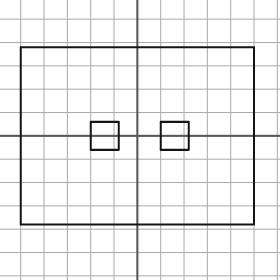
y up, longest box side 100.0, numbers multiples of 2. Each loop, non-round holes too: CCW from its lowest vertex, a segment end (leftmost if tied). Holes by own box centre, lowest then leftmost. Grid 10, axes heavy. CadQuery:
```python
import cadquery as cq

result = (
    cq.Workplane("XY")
    .moveTo(-50.0, -38.0)
    .lineTo(50.0, -38.0)
    .lineTo(50.0, 38.0)
    .lineTo(-50.0, 38.0)
    .close()
    .moveTo(-20.0, -6.0)
    .lineTo(-8.0, -6.0)
    .lineTo(-8.0, 6.0)
    .lineTo(-20.0, 6.0)
    .close()
    .moveTo(10.0, -6.0)
    .lineTo(22.0, -6.0)
    .lineTo(22.0, 6.0)
    .lineTo(10.0, 6.0)
    .close()
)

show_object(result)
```